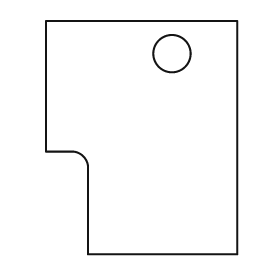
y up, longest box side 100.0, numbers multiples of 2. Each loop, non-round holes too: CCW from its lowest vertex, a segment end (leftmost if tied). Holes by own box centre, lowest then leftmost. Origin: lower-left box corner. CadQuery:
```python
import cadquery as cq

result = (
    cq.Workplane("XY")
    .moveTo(18.0, 0.0)
    .lineTo(82.0, 0.0)
    .lineTo(82.0, 100.0)
    .lineTo(0.0, 100.0)
    .lineTo(0.0, 44.0)
    .lineTo(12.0, 44.0)
    .threePointArc((16.0, 42.0), (18.0, 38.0))
    .close()
    .moveTo(54.0, 86.0)
    .circle(8.0)
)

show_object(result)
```